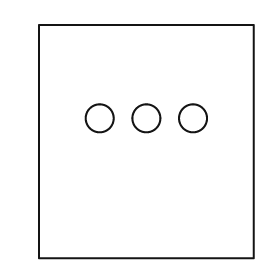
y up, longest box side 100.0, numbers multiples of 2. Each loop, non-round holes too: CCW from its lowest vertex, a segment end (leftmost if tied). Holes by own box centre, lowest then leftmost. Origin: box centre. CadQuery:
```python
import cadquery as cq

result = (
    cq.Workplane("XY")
    .moveTo(-46.0, -50.0)
    .lineTo(46.0, -50.0)
    .lineTo(46.0, 50.0)
    .lineTo(-46.0, 50.0)
    .close()
    .moveTo(-20.0, 10.0)
    .circle(6.0)
    .moveTo(0.0, 10.0)
    .circle(6.0)
    .moveTo(20.0, 10.0)
    .circle(6.0)
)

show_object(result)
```